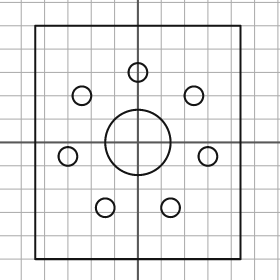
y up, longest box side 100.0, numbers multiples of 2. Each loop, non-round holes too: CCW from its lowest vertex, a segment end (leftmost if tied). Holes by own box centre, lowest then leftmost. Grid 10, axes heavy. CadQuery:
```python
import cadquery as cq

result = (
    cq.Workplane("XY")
    .moveTo(-44.0, -50.0)
    .lineTo(44.0, -50.0)
    .lineTo(44.0, 50.0)
    .lineTo(-44.0, 50.0)
    .close()
    .moveTo(-14.0, -28.0)
    .circle(4.0)
    .moveTo(14.0, -28.0)
    .circle(4.0)
    .moveTo(-30.0, -6.0)
    .circle(4.0)
    .moveTo(30.0, -6.0)
    .circle(4.0)
    .moveTo(0.0, 0.0)
    .circle(14.0)
    .moveTo(-24.0, 20.0)
    .circle(4.0)
    .moveTo(24.0, 20.0)
    .circle(4.0)
    .moveTo(0.0, 30.0)
    .circle(4.0)
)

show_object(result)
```